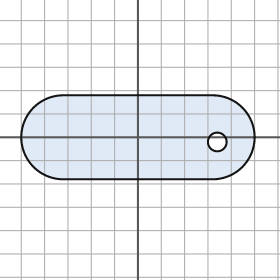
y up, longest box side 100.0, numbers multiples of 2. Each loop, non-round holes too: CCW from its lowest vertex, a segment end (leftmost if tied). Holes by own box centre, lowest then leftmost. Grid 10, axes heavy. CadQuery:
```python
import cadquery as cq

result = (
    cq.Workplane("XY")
    .moveTo(-32.0, -18.0)
    .lineTo(32.0, -18.0)
    .threePointArc((50.0, 0.0), (32.0, 18.0))
    .lineTo(-32.0, 18.0)
    .threePointArc((-50.0, 0.0), (-32.0, -18.0))
    .close()
    .moveTo(34.0, -2.0)
    .circle(4.0)
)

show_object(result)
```